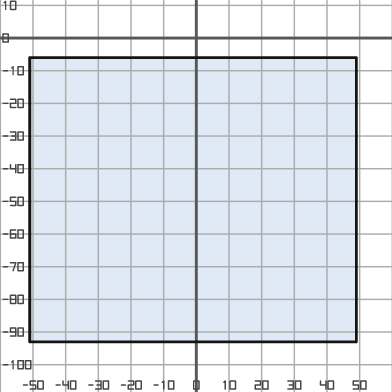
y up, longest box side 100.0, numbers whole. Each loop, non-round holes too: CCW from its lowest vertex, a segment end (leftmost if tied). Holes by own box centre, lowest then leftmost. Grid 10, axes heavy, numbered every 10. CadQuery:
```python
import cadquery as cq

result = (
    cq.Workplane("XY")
    .moveTo(-51.0, -93.0)
    .lineTo(49.0, -93.0)
    .lineTo(49.0, -6.0)
    .lineTo(-51.0, -6.0)
    .close()
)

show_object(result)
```